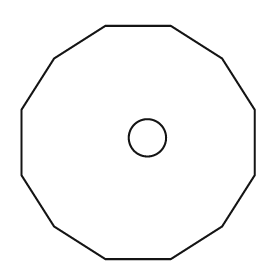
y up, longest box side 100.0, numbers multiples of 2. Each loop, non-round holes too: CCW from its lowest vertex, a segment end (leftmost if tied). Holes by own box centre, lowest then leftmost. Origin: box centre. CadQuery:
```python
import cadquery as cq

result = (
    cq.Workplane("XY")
    .moveTo(-14.0, -50.0)
    .lineTo(14.0, -50.0)
    .lineTo(36.0, -36.0)
    .lineTo(50.0, -14.0)
    .lineTo(50.0, 14.0)
    .lineTo(36.0, 36.0)
    .lineTo(14.0, 50.0)
    .lineTo(-14.0, 50.0)
    .lineTo(-36.0, 36.0)
    .lineTo(-50.0, 14.0)
    .lineTo(-50.0, -14.0)
    .lineTo(-36.0, -36.0)
    .close()
    .moveTo(4.0, 2.0)
    .circle(8.0)
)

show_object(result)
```